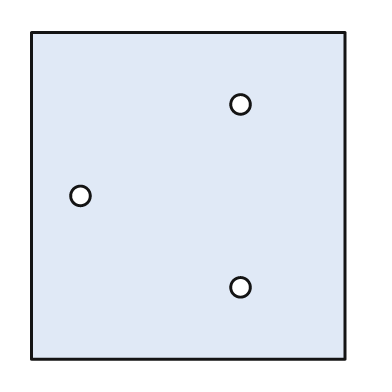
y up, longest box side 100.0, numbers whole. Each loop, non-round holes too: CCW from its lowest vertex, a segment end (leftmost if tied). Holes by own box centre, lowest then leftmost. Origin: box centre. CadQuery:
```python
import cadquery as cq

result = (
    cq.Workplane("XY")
    .moveTo(-48.0, -50.0)
    .lineTo(48.0, -50.0)
    .lineTo(48.0, 50.0)
    .lineTo(-48.0, 50.0)
    .close()
    .moveTo(16.0, -28.0)
    .circle(3.0)
    .moveTo(-33.0, 0.0)
    .circle(3.0)
    .moveTo(16.0, 28.0)
    .circle(3.0)
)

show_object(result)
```